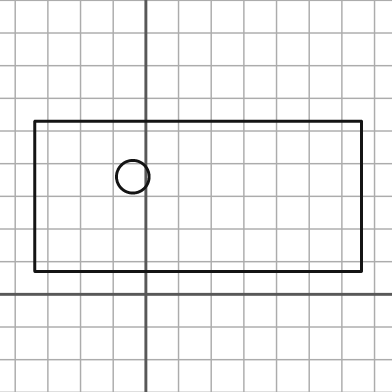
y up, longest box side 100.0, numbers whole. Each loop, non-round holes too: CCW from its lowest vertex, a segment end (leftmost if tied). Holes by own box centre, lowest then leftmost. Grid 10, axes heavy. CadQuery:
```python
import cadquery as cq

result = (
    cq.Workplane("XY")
    .moveTo(-34.0, 7.0)
    .lineTo(66.0, 7.0)
    .lineTo(66.0, 53.0)
    .lineTo(-34.0, 53.0)
    .close()
    .moveTo(-4.0, 36.0)
    .circle(5.0)
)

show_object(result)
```